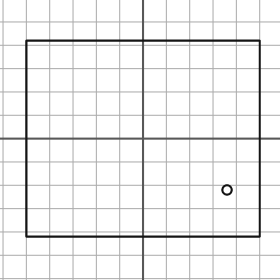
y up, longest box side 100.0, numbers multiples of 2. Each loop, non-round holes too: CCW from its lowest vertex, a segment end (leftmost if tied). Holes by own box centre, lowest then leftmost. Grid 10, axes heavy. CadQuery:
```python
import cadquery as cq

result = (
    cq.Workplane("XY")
    .moveTo(-50.0, -42.0)
    .lineTo(50.0, -42.0)
    .lineTo(50.0, 42.0)
    .lineTo(-50.0, 42.0)
    .close()
    .moveTo(36.0, -22.0)
    .circle(2.0)
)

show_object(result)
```